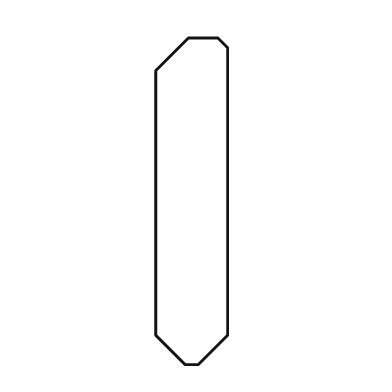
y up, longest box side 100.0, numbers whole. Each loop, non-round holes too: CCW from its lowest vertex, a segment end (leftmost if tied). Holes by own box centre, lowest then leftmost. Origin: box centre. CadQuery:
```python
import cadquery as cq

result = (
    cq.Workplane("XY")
    .moveTo(-2.0, -50.0)
    .lineTo(2.0, -50.0)
    .lineTo(11.0, -41.0)
    .lineTo(11.0, 47.0)
    .lineTo(8.0, 50.0)
    .lineTo(-1.0, 50.0)
    .lineTo(-11.0, 40.0)
    .lineTo(-11.0, -41.0)
    .close()
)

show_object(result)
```